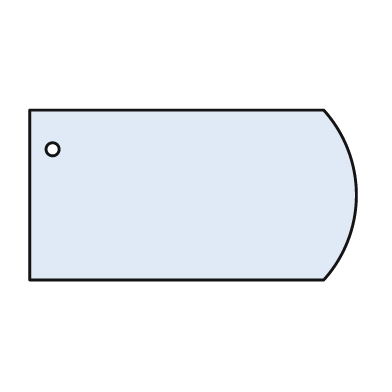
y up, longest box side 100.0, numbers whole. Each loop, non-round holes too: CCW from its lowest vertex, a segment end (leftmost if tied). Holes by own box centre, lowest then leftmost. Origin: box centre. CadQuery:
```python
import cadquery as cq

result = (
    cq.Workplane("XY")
    .moveTo(-50.0, -26.0)
    .lineTo(40.0, -26.0)
    .threePointArc((50.0, 0.0), (40.0, 26.0))
    .lineTo(-50.0, 26.0)
    .close()
    .moveTo(-43.0, 14.0)
    .circle(2.0)
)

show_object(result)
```